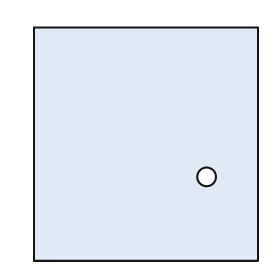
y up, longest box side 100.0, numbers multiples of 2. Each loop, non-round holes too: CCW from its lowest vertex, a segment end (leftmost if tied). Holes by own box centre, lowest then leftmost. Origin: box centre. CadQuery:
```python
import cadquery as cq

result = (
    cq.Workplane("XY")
    .moveTo(-48.0, -50.0)
    .lineTo(48.0, -50.0)
    .lineTo(48.0, 50.0)
    .lineTo(-48.0, 50.0)
    .close()
    .moveTo(26.0, -14.0)
    .circle(4.0)
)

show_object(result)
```